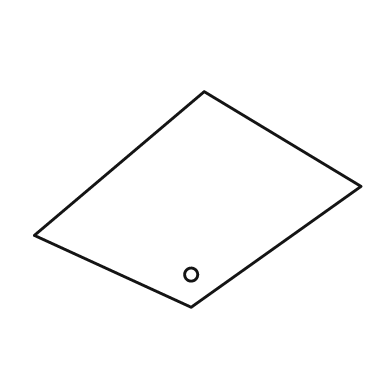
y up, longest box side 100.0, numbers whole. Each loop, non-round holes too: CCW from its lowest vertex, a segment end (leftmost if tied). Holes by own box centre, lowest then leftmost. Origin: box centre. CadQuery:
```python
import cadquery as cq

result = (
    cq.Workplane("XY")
    .moveTo(-2.0, -33.0)
    .lineTo(50.0, 4.0)
    .lineTo(2.0, 33.0)
    .lineTo(-50.0, -11.0)
    .close()
    .moveTo(-2.0, -23.0)
    .circle(2.0)
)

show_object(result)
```